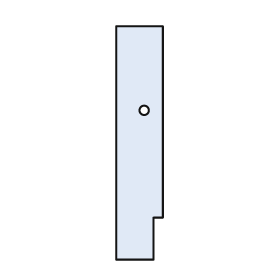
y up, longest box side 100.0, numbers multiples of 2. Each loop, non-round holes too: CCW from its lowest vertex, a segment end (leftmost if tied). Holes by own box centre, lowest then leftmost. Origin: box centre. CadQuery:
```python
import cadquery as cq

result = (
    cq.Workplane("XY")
    .moveTo(-10.0, -50.0)
    .lineTo(6.0, -50.0)
    .lineTo(6.0, -32.0)
    .lineTo(10.0, -32.0)
    .lineTo(10.0, 50.0)
    .lineTo(-10.0, 50.0)
    .close()
    .moveTo(2.0, 14.0)
    .circle(2.0)
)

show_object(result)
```